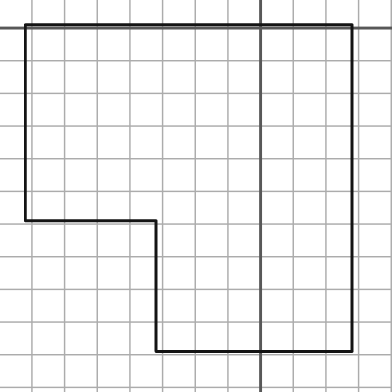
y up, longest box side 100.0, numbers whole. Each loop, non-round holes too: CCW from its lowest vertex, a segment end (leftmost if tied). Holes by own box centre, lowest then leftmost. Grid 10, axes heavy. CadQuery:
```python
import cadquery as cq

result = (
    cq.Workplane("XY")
    .moveTo(-32.0, -99.0)
    .lineTo(28.0, -99.0)
    .lineTo(28.0, 1.0)
    .lineTo(-72.0, 1.0)
    .lineTo(-72.0, -59.0)
    .lineTo(-32.0, -59.0)
    .close()
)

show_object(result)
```